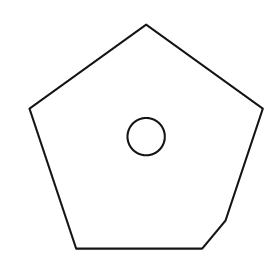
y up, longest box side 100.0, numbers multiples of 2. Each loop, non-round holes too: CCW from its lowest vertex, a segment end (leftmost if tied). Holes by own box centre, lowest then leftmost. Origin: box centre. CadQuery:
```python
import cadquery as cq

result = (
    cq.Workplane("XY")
    .moveTo(-30.0, -48.0)
    .lineTo(24.0, -48.0)
    .lineTo(34.0, -36.0)
    .lineTo(50.0, 12.0)
    .lineTo(0.0, 48.0)
    .lineTo(-50.0, 12.0)
    .close()
    .moveTo(0.0, 0.0)
    .circle(8.0)
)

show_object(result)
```